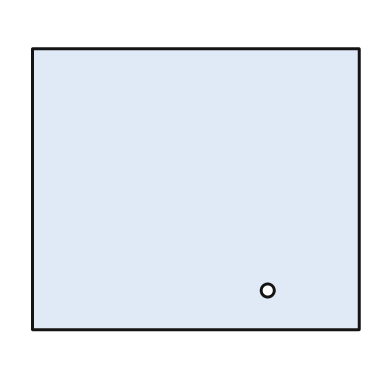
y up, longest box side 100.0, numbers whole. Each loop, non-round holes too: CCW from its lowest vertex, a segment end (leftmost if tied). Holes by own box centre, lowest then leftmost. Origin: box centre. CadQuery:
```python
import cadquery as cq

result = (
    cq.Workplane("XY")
    .moveTo(-50.0, -43.0)
    .lineTo(50.0, -43.0)
    .lineTo(50.0, 43.0)
    .lineTo(-50.0, 43.0)
    .close()
    .moveTo(22.0, -31.0)
    .circle(2.0)
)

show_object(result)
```